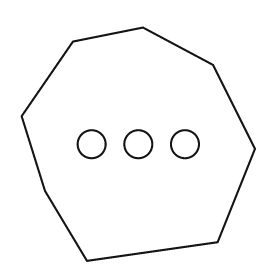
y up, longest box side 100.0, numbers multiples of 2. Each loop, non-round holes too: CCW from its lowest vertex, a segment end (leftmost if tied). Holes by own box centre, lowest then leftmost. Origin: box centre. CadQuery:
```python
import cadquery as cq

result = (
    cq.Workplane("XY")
    .moveTo(-22.0, -50.0)
    .lineTo(34.0, -42.0)
    .lineTo(50.0, -2.0)
    .lineTo(32.0, 34.0)
    .lineTo(2.0, 50.0)
    .lineTo(-28.0, 44.0)
    .lineTo(-50.0, 12.0)
    .lineTo(-40.0, -20.0)
    .close()
    .moveTo(-20.0, 0.0)
    .circle(6.0)
    .moveTo(0.0, 0.0)
    .circle(6.0)
    .moveTo(20.0, 0.0)
    .circle(6.0)
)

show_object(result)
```